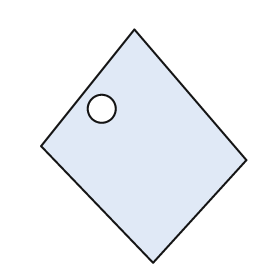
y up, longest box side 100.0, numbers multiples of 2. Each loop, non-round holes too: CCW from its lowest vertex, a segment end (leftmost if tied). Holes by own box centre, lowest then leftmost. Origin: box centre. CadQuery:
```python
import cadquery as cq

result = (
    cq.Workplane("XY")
    .moveTo(4.0, -50.0)
    .lineTo(44.0, -6.0)
    .lineTo(-4.0, 50.0)
    .lineTo(-44.0, 0.0)
    .close()
    .moveTo(-18.0, 16.0)
    .circle(6.0)
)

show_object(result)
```